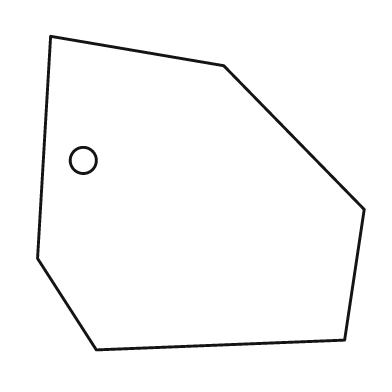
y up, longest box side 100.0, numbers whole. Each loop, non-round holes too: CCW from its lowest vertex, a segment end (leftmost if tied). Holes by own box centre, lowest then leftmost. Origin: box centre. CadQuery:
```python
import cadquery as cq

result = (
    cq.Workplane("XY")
    .moveTo(-32.0, -48.0)
    .lineTo(44.0, -45.0)
    .lineTo(50.0, -5.0)
    .lineTo(7.0, 39.0)
    .lineTo(-46.0, 48.0)
    .lineTo(-50.0, -20.0)
    .close()
    .moveTo(-36.0, 10.0)
    .circle(4.0)
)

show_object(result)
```